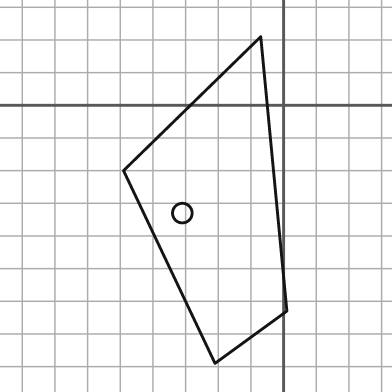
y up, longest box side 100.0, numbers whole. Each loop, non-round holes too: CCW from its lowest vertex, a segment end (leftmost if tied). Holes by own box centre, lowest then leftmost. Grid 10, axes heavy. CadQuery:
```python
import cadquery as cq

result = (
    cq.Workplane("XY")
    .moveTo(-21.0, -79.0)
    .lineTo(1.0, -63.0)
    .lineTo(-7.0, 21.0)
    .lineTo(-49.0, -20.0)
    .close()
    .moveTo(-31.0, -33.0)
    .circle(3.0)
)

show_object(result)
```